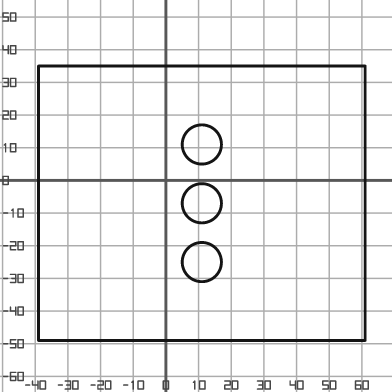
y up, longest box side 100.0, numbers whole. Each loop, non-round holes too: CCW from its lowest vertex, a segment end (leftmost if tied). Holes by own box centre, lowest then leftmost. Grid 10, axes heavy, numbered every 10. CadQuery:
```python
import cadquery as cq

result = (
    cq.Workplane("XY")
    .moveTo(-39.0, -49.0)
    .lineTo(61.0, -49.0)
    .lineTo(61.0, 35.0)
    .lineTo(-39.0, 35.0)
    .close()
    .moveTo(11.0, -25.0)
    .circle(6.0)
    .moveTo(11.0, -7.0)
    .circle(6.0)
    .moveTo(11.0, 11.0)
    .circle(6.0)
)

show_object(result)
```